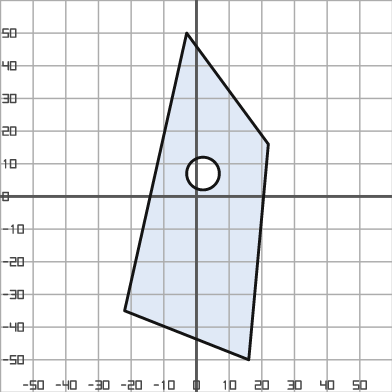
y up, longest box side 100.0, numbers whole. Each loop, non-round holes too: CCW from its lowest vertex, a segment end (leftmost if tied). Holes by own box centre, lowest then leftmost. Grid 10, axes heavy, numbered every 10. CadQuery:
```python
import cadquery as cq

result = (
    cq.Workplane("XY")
    .moveTo(16.0, -50.0)
    .lineTo(22.0, 16.0)
    .lineTo(-3.0, 50.0)
    .lineTo(-22.0, -35.0)
    .close()
    .moveTo(2.0, 7.0)
    .circle(5.0)
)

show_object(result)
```